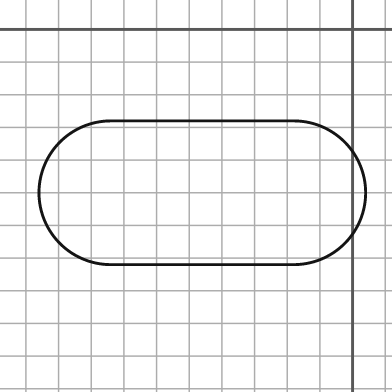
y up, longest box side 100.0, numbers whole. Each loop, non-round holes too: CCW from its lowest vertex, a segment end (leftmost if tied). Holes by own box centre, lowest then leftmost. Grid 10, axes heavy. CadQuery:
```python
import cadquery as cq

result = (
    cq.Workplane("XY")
    .moveTo(-74.0, -72.0)
    .lineTo(-18.0, -72.0)
    .threePointArc((4.0, -50.0), (-18.0, -28.0))
    .lineTo(-74.0, -28.0)
    .threePointArc((-96.0, -50.0), (-74.0, -72.0))
    .close()
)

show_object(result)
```